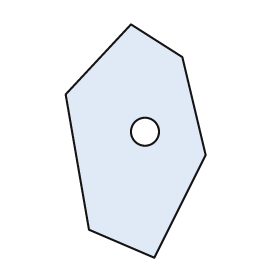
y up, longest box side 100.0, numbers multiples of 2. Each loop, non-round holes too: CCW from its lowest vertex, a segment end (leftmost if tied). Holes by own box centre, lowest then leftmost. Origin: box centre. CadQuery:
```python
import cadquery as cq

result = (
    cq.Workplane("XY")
    .moveTo(8.0, -50.0)
    .lineTo(30.0, -6.0)
    .lineTo(20.0, 36.0)
    .lineTo(-2.0, 50.0)
    .lineTo(-30.0, 20.0)
    .lineTo(-20.0, -38.0)
    .close()
    .moveTo(4.0, 4.0)
    .circle(6.0)
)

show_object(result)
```